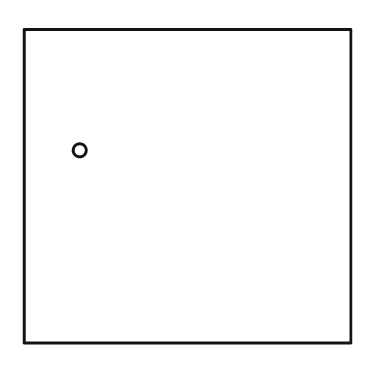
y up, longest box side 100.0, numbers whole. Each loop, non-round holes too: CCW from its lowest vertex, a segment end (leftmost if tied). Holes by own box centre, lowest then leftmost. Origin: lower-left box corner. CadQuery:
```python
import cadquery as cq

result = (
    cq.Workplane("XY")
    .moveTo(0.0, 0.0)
    .lineTo(100.0, 0.0)
    .lineTo(100.0, 96.0)
    .lineTo(0.0, 96.0)
    .close()
    .moveTo(17.0, 59.0)
    .circle(2.0)
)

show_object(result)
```